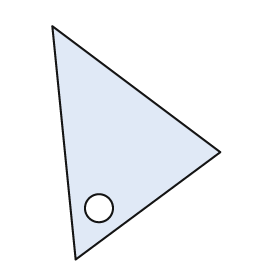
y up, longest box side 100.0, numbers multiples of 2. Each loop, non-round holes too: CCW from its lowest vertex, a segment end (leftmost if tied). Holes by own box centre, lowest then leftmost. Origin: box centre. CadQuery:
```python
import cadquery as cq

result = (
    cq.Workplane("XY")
    .moveTo(-26.0, -50.0)
    .lineTo(36.0, -4.0)
    .lineTo(-36.0, 50.0)
    .close()
    .moveTo(-16.0, -28.0)
    .circle(6.0)
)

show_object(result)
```